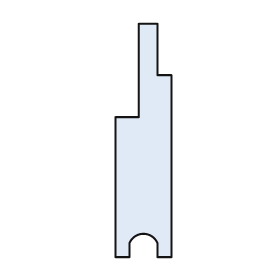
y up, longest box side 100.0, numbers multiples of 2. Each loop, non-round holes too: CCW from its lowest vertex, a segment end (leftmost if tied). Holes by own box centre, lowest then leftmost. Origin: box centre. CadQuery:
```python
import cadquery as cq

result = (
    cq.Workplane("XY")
    .moveTo(-12.0, -50.0)
    .lineTo(-6.0, -50.0)
    .lineTo(-6.0, -44.0)
    .threePointArc((0.0, -40.0), (6.0, -44.0))
    .lineTo(6.0, -50.0)
    .lineTo(12.0, -50.0)
    .lineTo(12.0, 28.0)
    .lineTo(6.0, 28.0)
    .lineTo(6.0, 50.0)
    .lineTo(-2.0, 50.0)
    .lineTo(-2.0, 10.0)
    .lineTo(-12.0, 10.0)
    .close()
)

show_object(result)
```